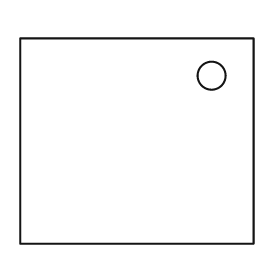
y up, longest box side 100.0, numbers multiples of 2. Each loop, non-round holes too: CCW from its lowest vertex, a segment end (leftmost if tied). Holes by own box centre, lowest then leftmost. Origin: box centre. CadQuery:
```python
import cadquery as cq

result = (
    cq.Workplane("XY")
    .moveTo(-50.0, -44.0)
    .lineTo(50.0, -44.0)
    .lineTo(50.0, 44.0)
    .lineTo(-50.0, 44.0)
    .close()
    .moveTo(32.0, 28.0)
    .circle(6.0)
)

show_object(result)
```